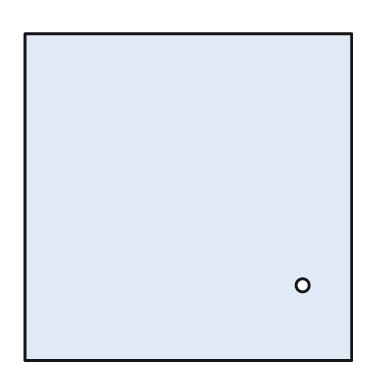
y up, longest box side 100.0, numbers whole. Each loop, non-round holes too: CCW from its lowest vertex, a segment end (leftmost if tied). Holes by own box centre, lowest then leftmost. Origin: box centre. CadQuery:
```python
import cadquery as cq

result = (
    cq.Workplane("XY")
    .moveTo(-50.0, -50.0)
    .lineTo(50.0, -50.0)
    .lineTo(50.0, 50.0)
    .lineTo(-50.0, 50.0)
    .close()
    .moveTo(35.0, -27.0)
    .circle(2.0)
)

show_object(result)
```